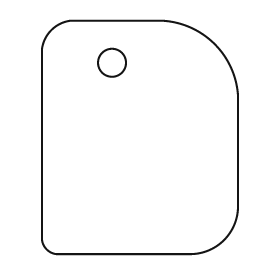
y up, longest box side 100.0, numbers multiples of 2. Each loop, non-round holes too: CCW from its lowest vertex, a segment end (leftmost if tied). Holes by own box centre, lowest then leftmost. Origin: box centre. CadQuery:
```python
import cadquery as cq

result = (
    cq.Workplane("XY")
    .moveTo(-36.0, -50.0)
    .lineTo(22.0, -50.0)
    .threePointArc((36.0, -44.0), (42.0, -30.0))
    .lineTo(42.0, 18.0)
    .threePointArc((32.0, 40.0), (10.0, 50.0))
    .lineTo(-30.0, 50.0)
    .threePointArc((-38.0, 46.0), (-42.0, 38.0))
    .lineTo(-42.0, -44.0)
    .threePointArc((-40.0, -48.0), (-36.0, -50.0))
    .close()
    .moveTo(-12.0, 32.0)
    .circle(6.0)
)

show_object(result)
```